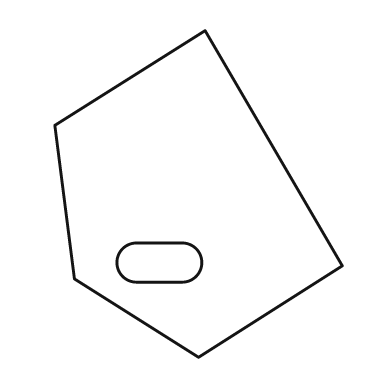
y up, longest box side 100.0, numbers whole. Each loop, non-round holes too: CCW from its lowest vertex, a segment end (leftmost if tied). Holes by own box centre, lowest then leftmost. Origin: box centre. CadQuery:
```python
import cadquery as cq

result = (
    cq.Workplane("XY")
    .moveTo(0.0, -50.0)
    .lineTo(44.0, -22.0)
    .lineTo(2.0, 50.0)
    .lineTo(-44.0, 21.0)
    .lineTo(-38.0, -26.0)
    .close()
    .moveTo(-19.0, -27.0)
    .lineTo(-5.0, -27.0)
    .threePointArc((1.0, -21.0), (-5.0, -15.0))
    .lineTo(-19.0, -15.0)
    .threePointArc((-25.0, -21.0), (-19.0, -27.0))
    .close()
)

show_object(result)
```